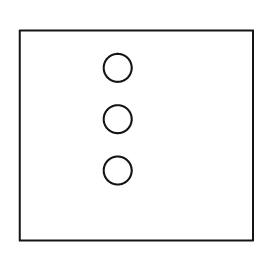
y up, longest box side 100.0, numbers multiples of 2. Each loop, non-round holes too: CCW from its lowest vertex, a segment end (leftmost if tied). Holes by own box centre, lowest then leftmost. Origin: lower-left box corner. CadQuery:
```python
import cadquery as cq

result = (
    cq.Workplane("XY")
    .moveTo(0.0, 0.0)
    .lineTo(100.0, 0.0)
    .lineTo(100.0, 90.0)
    .lineTo(0.0, 90.0)
    .close()
    .moveTo(42.0, 30.0)
    .circle(6.0)
    .moveTo(42.0, 52.0)
    .circle(6.0)
    .moveTo(42.0, 74.0)
    .circle(6.0)
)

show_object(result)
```